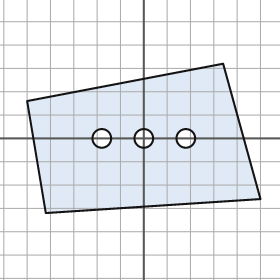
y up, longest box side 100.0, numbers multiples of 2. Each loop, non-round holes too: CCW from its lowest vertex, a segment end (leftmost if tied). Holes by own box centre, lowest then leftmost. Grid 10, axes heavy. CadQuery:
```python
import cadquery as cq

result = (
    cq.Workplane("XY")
    .moveTo(-42.0, -32.0)
    .lineTo(50.0, -26.0)
    .lineTo(34.0, 32.0)
    .lineTo(-50.0, 16.0)
    .close()
    .moveTo(-18.0, 0.0)
    .circle(4.0)
    .moveTo(0.0, 0.0)
    .circle(4.0)
    .moveTo(18.0, 0.0)
    .circle(4.0)
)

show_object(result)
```